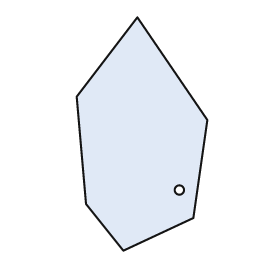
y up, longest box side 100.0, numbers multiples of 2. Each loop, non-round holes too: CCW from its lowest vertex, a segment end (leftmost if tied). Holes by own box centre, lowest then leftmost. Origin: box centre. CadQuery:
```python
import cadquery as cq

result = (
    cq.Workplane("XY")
    .moveTo(-8.0, -50.0)
    .lineTo(22.0, -36.0)
    .lineTo(28.0, 6.0)
    .lineTo(-2.0, 50.0)
    .lineTo(-28.0, 16.0)
    .lineTo(-24.0, -30.0)
    .close()
    .moveTo(16.0, -24.0)
    .circle(2.0)
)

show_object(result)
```